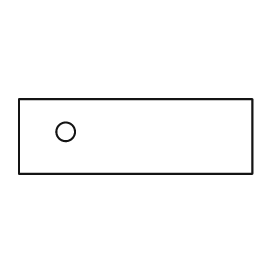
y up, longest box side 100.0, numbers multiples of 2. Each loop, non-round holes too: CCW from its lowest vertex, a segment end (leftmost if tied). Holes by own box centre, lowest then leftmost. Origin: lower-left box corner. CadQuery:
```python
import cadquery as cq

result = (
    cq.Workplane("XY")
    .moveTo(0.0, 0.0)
    .lineTo(100.0, 0.0)
    .lineTo(100.0, 32.0)
    .lineTo(0.0, 32.0)
    .close()
    .moveTo(20.0, 18.0)
    .circle(4.0)
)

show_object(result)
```